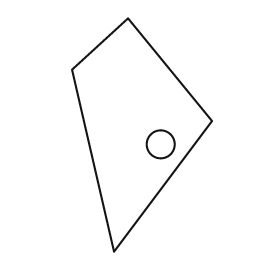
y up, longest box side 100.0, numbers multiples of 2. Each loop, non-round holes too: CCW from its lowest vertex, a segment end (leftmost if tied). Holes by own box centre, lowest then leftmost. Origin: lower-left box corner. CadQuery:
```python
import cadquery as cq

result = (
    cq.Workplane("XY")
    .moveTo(18.0, 0.0)
    .lineTo(60.0, 56.0)
    .lineTo(24.0, 100.0)
    .lineTo(0.0, 78.0)
    .close()
    .moveTo(38.0, 46.0)
    .circle(6.0)
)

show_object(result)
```